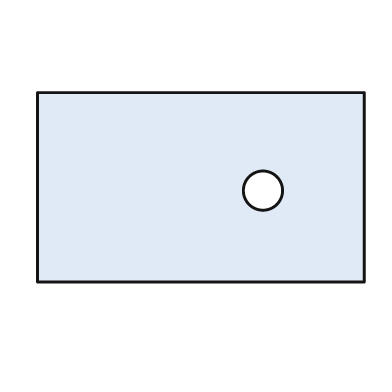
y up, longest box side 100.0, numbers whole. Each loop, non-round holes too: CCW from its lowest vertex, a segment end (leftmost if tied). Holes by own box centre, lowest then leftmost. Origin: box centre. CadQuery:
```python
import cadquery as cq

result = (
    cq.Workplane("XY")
    .moveTo(-50.0, -29.0)
    .lineTo(50.0, -29.0)
    .lineTo(50.0, 29.0)
    .lineTo(-50.0, 29.0)
    .close()
    .moveTo(19.0, -1.0)
    .circle(6.0)
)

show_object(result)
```